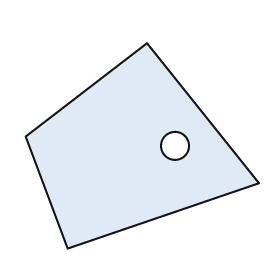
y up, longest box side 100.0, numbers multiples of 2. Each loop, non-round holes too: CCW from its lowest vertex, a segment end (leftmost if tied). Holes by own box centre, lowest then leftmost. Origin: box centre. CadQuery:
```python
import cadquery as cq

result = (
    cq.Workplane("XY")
    .moveTo(-32.0, -44.0)
    .lineTo(50.0, -16.0)
    .lineTo(2.0, 44.0)
    .lineTo(-50.0, 4.0)
    .close()
    .moveTo(14.0, 0.0)
    .circle(6.0)
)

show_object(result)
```